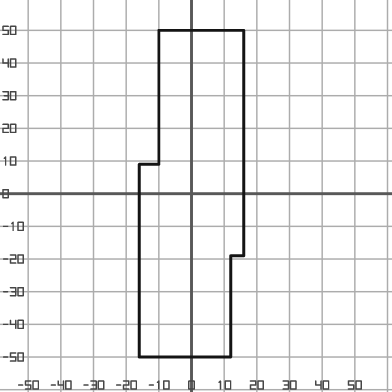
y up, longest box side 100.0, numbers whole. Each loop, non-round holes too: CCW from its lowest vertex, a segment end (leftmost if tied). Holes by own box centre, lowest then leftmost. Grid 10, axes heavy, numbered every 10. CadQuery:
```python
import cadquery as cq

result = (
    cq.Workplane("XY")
    .moveTo(-16.0, -50.0)
    .lineTo(12.0, -50.0)
    .lineTo(12.0, -19.0)
    .lineTo(16.0, -19.0)
    .lineTo(16.0, 50.0)
    .lineTo(-10.0, 50.0)
    .lineTo(-10.0, 9.0)
    .lineTo(-16.0, 9.0)
    .close()
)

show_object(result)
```